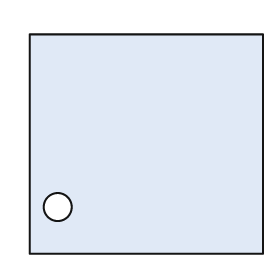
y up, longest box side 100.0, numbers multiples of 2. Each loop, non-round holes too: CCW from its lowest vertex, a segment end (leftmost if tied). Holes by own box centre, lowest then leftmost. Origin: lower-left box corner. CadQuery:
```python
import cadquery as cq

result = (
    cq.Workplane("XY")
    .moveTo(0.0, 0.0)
    .lineTo(100.0, 0.0)
    .lineTo(100.0, 94.0)
    .lineTo(0.0, 94.0)
    .close()
    .moveTo(12.0, 20.0)
    .circle(6.0)
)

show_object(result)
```